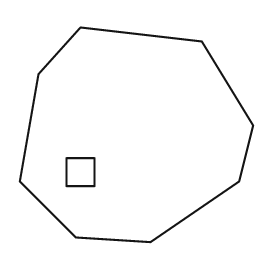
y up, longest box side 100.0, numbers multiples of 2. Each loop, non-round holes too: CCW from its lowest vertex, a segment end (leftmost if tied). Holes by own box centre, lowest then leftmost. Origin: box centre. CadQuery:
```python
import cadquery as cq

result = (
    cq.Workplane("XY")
    .moveTo(6.0, -46.0)
    .lineTo(44.0, -20.0)
    .lineTo(50.0, 4.0)
    .lineTo(28.0, 40.0)
    .lineTo(-24.0, 46.0)
    .lineTo(-42.0, 26.0)
    .lineTo(-50.0, -20.0)
    .lineTo(-26.0, -44.0)
    .close()
    .moveTo(-30.0, -22.0)
    .lineTo(-18.0, -22.0)
    .lineTo(-18.0, -10.0)
    .lineTo(-30.0, -10.0)
    .close()
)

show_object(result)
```